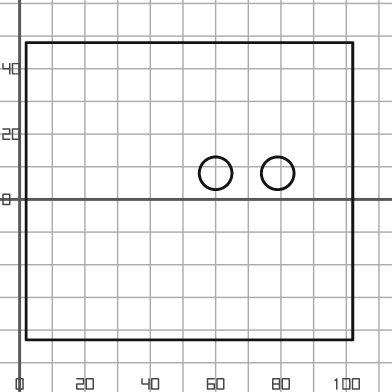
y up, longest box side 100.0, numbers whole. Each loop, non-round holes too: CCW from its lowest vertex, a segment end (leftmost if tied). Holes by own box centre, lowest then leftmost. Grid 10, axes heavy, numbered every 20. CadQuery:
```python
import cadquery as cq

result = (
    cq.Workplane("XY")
    .moveTo(2.0, -43.0)
    .lineTo(102.0, -43.0)
    .lineTo(102.0, 48.0)
    .lineTo(2.0, 48.0)
    .close()
    .moveTo(60.0, 8.0)
    .circle(5.0)
    .moveTo(79.0, 8.0)
    .circle(5.0)
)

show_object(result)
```